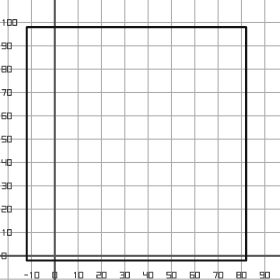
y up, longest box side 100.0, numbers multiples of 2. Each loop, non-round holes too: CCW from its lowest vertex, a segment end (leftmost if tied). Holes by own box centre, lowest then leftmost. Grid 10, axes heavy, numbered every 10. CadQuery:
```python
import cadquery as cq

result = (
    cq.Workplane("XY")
    .moveTo(-12.0, -2.0)
    .lineTo(82.0, -2.0)
    .lineTo(82.0, 98.0)
    .lineTo(-12.0, 98.0)
    .close()
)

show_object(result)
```